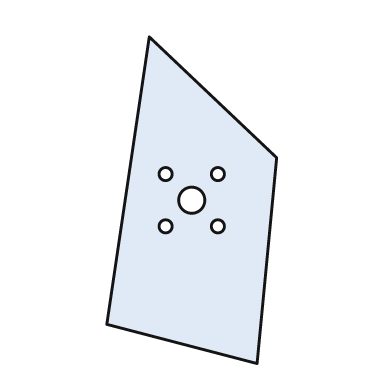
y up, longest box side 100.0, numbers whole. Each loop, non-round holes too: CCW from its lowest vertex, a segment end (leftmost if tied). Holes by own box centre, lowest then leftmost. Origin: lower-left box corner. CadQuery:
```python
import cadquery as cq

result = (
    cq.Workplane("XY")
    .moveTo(46.0, 0.0)
    .lineTo(52.0, 63.0)
    .lineTo(13.0, 100.0)
    .lineTo(0.0, 12.0)
    .close()
    .moveTo(18.0, 42.0)
    .circle(2.0)
    .moveTo(34.0, 42.0)
    .circle(2.0)
    .moveTo(26.0, 50.0)
    .circle(4.0)
    .moveTo(18.0, 58.0)
    .circle(2.0)
    .moveTo(34.0, 58.0)
    .circle(2.0)
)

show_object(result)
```